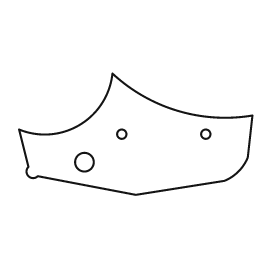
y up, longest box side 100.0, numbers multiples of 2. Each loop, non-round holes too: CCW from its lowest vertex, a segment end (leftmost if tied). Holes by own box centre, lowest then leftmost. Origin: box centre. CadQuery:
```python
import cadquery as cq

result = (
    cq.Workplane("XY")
    .moveTo(0.0, -26.0)
    .lineTo(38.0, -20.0)
    .threePointArc((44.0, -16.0), (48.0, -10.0))
    .lineTo(50.0, 8.0)
    .threePointArc((18.0, 10.0), (-10.0, 26.0))
    .threePointArc((-24.0, 4.0), (-50.0, 2.0))
    .lineTo(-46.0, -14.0)
    .threePointArc((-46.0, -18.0), (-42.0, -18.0))
    .close()
    .moveTo(-22.0, -12.0)
    .circle(4.0)
    .moveTo(-6.0, 0.0)
    .circle(2.0)
    .moveTo(30.0, 0.0)
    .circle(2.0)
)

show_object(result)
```